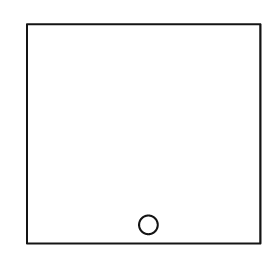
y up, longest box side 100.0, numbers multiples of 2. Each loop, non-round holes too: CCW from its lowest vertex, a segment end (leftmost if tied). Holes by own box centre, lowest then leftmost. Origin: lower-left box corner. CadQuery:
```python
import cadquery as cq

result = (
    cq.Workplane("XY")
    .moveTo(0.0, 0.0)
    .lineTo(100.0, 0.0)
    .lineTo(100.0, 94.0)
    .lineTo(0.0, 94.0)
    .close()
    .moveTo(52.0, 8.0)
    .circle(4.0)
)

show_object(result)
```